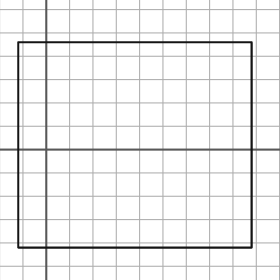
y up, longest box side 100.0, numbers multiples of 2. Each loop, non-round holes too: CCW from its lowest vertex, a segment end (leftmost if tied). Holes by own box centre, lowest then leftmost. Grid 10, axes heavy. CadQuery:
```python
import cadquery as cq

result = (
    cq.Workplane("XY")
    .moveTo(-12.0, -42.0)
    .lineTo(88.0, -42.0)
    .lineTo(88.0, 46.0)
    .lineTo(-12.0, 46.0)
    .close()
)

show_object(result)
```